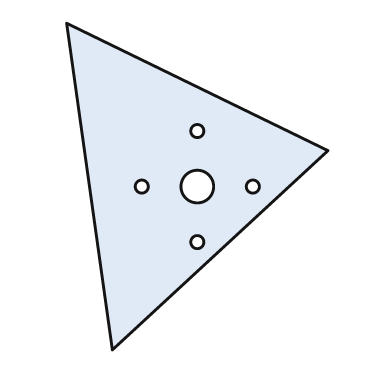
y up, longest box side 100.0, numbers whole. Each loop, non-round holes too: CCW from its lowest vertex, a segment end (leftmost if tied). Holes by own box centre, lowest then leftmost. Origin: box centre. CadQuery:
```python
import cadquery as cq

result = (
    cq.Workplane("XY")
    .moveTo(-26.0, -50.0)
    .lineTo(40.0, 11.0)
    .lineTo(-40.0, 50.0)
    .close()
    .moveTo(0.0, -17.0)
    .circle(2.0)
    .moveTo(-17.0, 0.0)
    .circle(2.0)
    .moveTo(0.0, 0.0)
    .circle(5.0)
    .moveTo(17.0, 0.0)
    .circle(2.0)
    .moveTo(0.0, 17.0)
    .circle(2.0)
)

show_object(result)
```